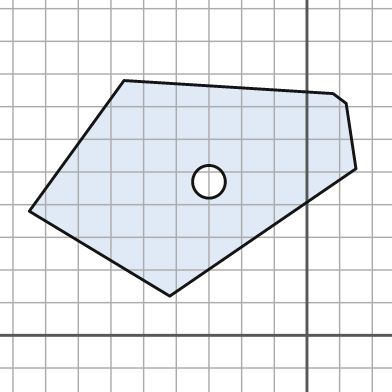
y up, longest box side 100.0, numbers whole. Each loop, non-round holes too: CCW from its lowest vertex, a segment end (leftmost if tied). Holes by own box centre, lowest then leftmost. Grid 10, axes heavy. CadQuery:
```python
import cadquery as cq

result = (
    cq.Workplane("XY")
    .moveTo(-42.0, 12.0)
    .lineTo(15.0, 51.0)
    .lineTo(12.0, 71.0)
    .lineTo(8.0, 74.0)
    .lineTo(-56.0, 78.0)
    .lineTo(-85.0, 38.0)
    .close()
    .moveTo(-30.0, 47.0)
    .circle(5.0)
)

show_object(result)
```